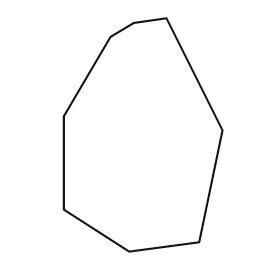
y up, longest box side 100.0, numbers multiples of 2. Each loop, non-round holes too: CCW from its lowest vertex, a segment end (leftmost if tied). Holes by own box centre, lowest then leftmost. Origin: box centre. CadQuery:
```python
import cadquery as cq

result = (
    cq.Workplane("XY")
    .moveTo(-6.0, -50.0)
    .lineTo(24.0, -46.0)
    .lineTo(34.0, 2.0)
    .lineTo(10.0, 50.0)
    .lineTo(-4.0, 48.0)
    .lineTo(-14.0, 42.0)
    .lineTo(-34.0, 8.0)
    .lineTo(-34.0, -32.0)
    .close()
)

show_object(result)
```